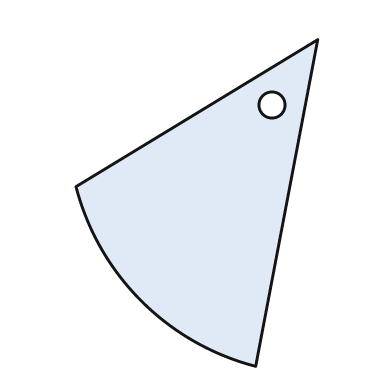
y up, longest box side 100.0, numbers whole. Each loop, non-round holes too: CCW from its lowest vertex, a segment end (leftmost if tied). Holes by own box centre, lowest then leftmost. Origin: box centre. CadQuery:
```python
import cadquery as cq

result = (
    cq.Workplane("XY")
    .moveTo(18.0, -50.0)
    .lineTo(37.0, 50.0)
    .lineTo(-37.0, 5.0)
    .threePointArc((-17.0, -30.0), (18.0, -50.0))
    .close()
    .moveTo(23.0, 30.0)
    .circle(4.0)
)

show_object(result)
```